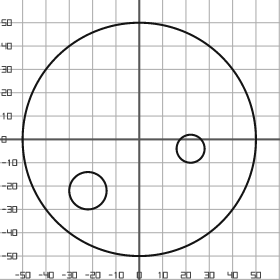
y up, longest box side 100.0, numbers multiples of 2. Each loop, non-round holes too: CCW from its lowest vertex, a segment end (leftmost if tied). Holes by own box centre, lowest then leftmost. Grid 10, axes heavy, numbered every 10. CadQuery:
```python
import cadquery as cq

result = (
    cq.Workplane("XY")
    .moveTo(0.0, 0.0)
    .circle(50.0)
    .moveTo(-22.0, -22.0)
    .circle(8.0)
    .moveTo(22.0, -4.0)
    .circle(6.0)
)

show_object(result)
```